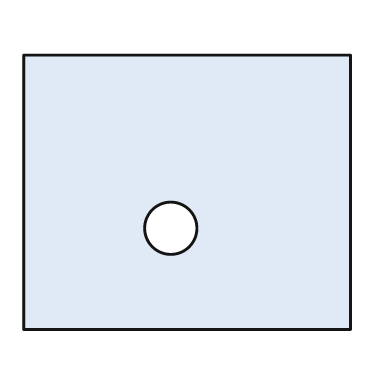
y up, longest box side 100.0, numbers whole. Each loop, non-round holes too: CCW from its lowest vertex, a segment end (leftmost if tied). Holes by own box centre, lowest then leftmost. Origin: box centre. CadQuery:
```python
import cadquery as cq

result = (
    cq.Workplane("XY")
    .moveTo(-50.0, -42.0)
    .lineTo(50.0, -42.0)
    .lineTo(50.0, 42.0)
    .lineTo(-50.0, 42.0)
    .close()
    .moveTo(-5.0, -11.0)
    .circle(8.0)
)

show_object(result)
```